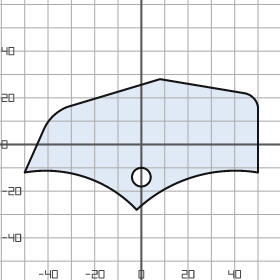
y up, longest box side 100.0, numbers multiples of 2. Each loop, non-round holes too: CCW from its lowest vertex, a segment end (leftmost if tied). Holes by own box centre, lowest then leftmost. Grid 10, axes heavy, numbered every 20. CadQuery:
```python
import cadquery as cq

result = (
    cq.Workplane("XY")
    .moveTo(-2.0, -28.0)
    .threePointArc((22.0, -14.0), (50.0, -12.0))
    .lineTo(50.0, 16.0)
    .threePointArc((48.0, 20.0), (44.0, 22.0))
    .lineTo(8.0, 28.0)
    .lineTo(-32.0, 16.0)
    .threePointArc((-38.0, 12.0), (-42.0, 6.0))
    .lineTo(-50.0, -12.0)
    .threePointArc((-24.0, -14.0), (-2.0, -28.0))
    .close()
    .moveTo(0.0, -14.0)
    .circle(4.0)
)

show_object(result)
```